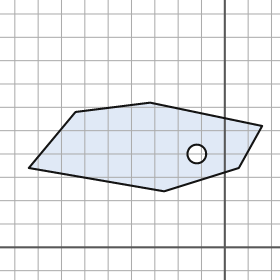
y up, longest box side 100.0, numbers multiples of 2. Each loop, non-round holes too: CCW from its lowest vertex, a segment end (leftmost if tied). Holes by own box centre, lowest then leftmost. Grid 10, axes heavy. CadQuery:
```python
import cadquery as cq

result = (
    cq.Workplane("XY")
    .moveTo(-26.0, 24.0)
    .lineTo(6.0, 34.0)
    .lineTo(16.0, 52.0)
    .lineTo(-32.0, 62.0)
    .lineTo(-64.0, 58.0)
    .lineTo(-84.0, 34.0)
    .close()
    .moveTo(-12.0, 40.0)
    .circle(4.0)
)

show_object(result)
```